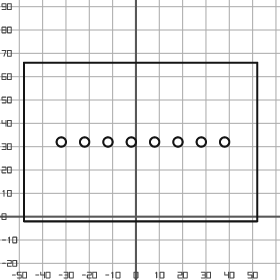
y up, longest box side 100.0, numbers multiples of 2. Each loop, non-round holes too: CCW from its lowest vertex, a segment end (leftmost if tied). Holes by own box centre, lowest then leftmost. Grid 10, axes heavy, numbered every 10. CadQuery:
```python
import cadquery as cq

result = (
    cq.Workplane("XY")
    .moveTo(-48.0, -2.0)
    .lineTo(52.0, -2.0)
    .lineTo(52.0, 66.0)
    .lineTo(-48.0, 66.0)
    .close()
    .moveTo(-32.0, 32.0)
    .circle(2.0)
    .moveTo(-22.0, 32.0)
    .circle(2.0)
    .moveTo(-12.0, 32.0)
    .circle(2.0)
    .moveTo(-2.0, 32.0)
    .circle(2.0)
    .moveTo(8.0, 32.0)
    .circle(2.0)
    .moveTo(18.0, 32.0)
    .circle(2.0)
    .moveTo(28.0, 32.0)
    .circle(2.0)
    .moveTo(38.0, 32.0)
    .circle(2.0)
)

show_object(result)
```